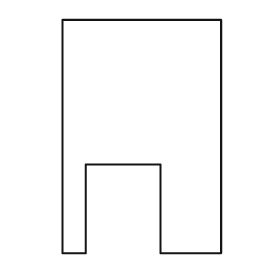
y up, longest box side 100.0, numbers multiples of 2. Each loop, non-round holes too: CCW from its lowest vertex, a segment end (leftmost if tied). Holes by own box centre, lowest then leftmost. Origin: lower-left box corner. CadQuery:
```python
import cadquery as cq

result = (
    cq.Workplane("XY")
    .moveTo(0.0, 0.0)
    .lineTo(10.0, 0.0)
    .lineTo(10.0, 38.0)
    .lineTo(42.0, 38.0)
    .lineTo(42.0, 0.0)
    .lineTo(68.0, 0.0)
    .lineTo(68.0, 100.0)
    .lineTo(0.0, 100.0)
    .close()
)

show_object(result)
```